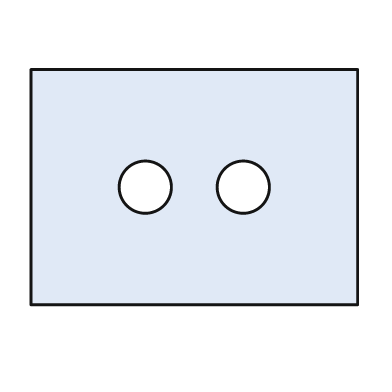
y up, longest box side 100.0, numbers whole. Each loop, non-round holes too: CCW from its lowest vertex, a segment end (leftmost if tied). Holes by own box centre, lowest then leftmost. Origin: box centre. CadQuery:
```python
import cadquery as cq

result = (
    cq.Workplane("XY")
    .moveTo(-50.0, -36.0)
    .lineTo(50.0, -36.0)
    .lineTo(50.0, 36.0)
    .lineTo(-50.0, 36.0)
    .close()
    .moveTo(-15.0, 0.0)
    .circle(8.0)
    .moveTo(15.0, 0.0)
    .circle(8.0)
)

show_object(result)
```